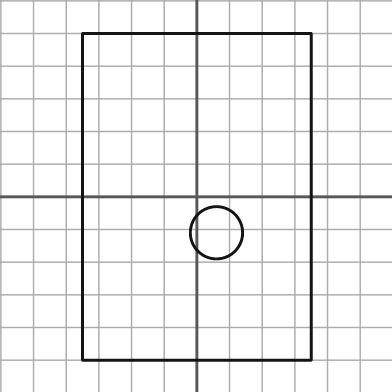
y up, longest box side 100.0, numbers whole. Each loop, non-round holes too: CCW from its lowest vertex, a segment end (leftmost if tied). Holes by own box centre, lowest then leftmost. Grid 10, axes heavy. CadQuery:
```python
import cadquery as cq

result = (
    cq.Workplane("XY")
    .moveTo(-35.0, -50.0)
    .lineTo(35.0, -50.0)
    .lineTo(35.0, 50.0)
    .lineTo(-35.0, 50.0)
    .close()
    .moveTo(6.0, -11.0)
    .circle(8.0)
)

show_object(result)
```